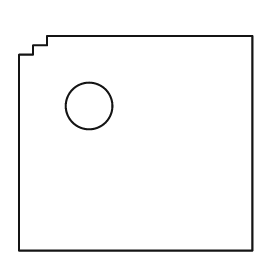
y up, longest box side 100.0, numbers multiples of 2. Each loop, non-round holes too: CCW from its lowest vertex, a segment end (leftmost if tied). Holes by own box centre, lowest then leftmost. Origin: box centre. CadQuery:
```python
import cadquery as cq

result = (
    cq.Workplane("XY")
    .moveTo(-50.0, -46.0)
    .lineTo(50.0, -46.0)
    .lineTo(50.0, 46.0)
    .lineTo(-38.0, 46.0)
    .lineTo(-38.0, 42.0)
    .lineTo(-44.0, 42.0)
    .lineTo(-44.0, 38.0)
    .lineTo(-50.0, 38.0)
    .close()
    .moveTo(-20.0, 16.0)
    .circle(10.0)
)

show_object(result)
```